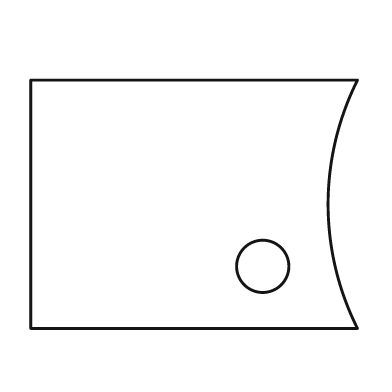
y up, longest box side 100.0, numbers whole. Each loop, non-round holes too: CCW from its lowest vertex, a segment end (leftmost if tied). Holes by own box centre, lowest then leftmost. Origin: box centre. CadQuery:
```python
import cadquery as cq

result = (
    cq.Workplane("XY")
    .moveTo(-50.0, -38.0)
    .lineTo(50.0, -38.0)
    .threePointArc((41.0, 0.0), (50.0, 38.0))
    .lineTo(-50.0, 38.0)
    .close()
    .moveTo(21.0, -19.0)
    .circle(8.0)
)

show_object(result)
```